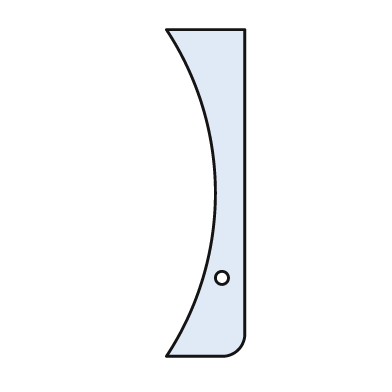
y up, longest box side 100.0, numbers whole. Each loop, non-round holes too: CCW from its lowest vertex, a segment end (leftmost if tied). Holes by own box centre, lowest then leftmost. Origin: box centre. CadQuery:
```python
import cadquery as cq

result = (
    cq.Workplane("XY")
    .moveTo(-12.0, -50.0)
    .lineTo(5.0, -50.0)
    .threePointArc((10.0, -48.0), (12.0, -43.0))
    .lineTo(12.0, 50.0)
    .lineTo(-12.0, 50.0)
    .threePointArc((3.0, 0.0), (-12.0, -50.0))
    .close()
    .moveTo(5.0, -26.0)
    .circle(2.0)
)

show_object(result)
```